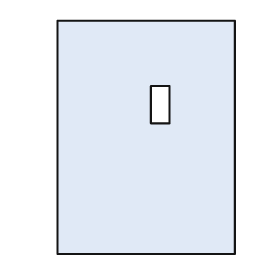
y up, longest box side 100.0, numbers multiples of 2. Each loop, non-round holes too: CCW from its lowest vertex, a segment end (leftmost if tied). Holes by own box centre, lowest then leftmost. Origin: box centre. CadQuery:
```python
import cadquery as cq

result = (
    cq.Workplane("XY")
    .moveTo(-38.0, -50.0)
    .lineTo(38.0, -50.0)
    .lineTo(38.0, 50.0)
    .lineTo(-38.0, 50.0)
    .close()
    .moveTo(2.0, 6.0)
    .lineTo(10.0, 6.0)
    .lineTo(10.0, 22.0)
    .lineTo(2.0, 22.0)
    .close()
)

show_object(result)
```